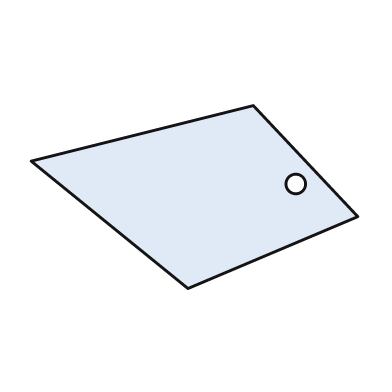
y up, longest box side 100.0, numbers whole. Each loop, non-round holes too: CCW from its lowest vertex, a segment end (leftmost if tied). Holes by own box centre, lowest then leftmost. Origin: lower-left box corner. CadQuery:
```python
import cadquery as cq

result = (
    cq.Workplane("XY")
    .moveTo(48.0, 0.0)
    .lineTo(100.0, 22.0)
    .lineTo(68.0, 56.0)
    .lineTo(0.0, 39.0)
    .close()
    .moveTo(81.0, 32.0)
    .circle(3.0)
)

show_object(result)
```